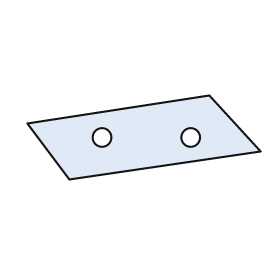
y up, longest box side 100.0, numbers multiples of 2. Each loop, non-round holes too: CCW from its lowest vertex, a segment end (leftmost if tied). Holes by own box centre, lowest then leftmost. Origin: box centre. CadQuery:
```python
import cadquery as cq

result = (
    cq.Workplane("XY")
    .moveTo(-32.0, -18.0)
    .lineTo(50.0, -6.0)
    .lineTo(28.0, 18.0)
    .lineTo(-50.0, 6.0)
    .close()
    .moveTo(-18.0, 0.0)
    .circle(4.0)
    .moveTo(20.0, 0.0)
    .circle(4.0)
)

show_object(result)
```